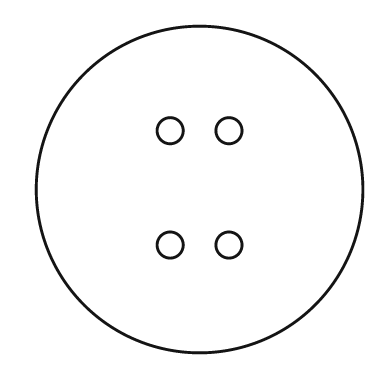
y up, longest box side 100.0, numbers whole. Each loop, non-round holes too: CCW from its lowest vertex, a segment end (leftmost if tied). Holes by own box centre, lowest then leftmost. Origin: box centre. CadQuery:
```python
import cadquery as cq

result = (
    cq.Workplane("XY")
    .moveTo(0.0, 0.0)
    .circle(50.0)
    .moveTo(-9.0, -17.0)
    .circle(4.0)
    .moveTo(9.0, -17.0)
    .circle(4.0)
    .moveTo(-9.0, 18.0)
    .circle(4.0)
    .moveTo(9.0, 18.0)
    .circle(4.0)
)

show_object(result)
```